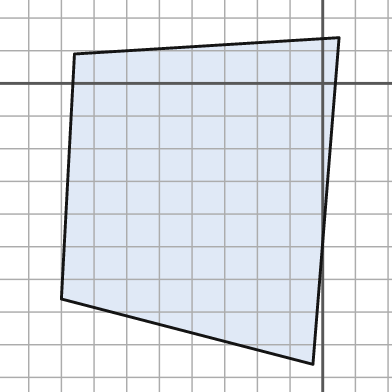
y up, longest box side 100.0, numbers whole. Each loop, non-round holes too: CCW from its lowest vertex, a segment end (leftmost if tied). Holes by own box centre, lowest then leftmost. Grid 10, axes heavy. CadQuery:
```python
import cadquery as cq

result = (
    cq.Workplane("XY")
    .moveTo(-3.0, -86.0)
    .lineTo(5.0, 14.0)
    .lineTo(-76.0, 9.0)
    .lineTo(-80.0, -66.0)
    .close()
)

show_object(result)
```